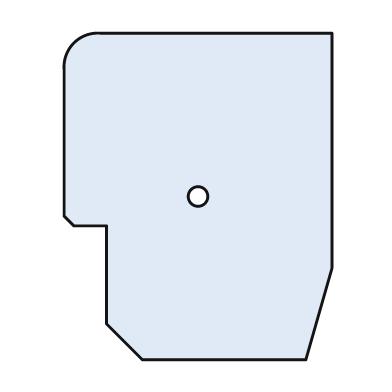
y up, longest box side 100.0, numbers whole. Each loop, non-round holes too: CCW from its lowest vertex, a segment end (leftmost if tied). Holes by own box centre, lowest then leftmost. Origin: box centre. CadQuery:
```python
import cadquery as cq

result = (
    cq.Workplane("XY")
    .moveTo(-17.0, -50.0)
    .lineTo(33.0, -50.0)
    .lineTo(41.0, -22.0)
    .lineTo(41.0, 50.0)
    .lineTo(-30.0, 50.0)
    .threePointArc((-38.0, 47.0), (-41.0, 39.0))
    .lineTo(-41.0, -6.0)
    .lineTo(-38.0, -9.0)
    .lineTo(-28.0, -9.0)
    .lineTo(-28.0, -39.0)
    .close()
    .moveTo(0.0, 0.0)
    .circle(3.0)
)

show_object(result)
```